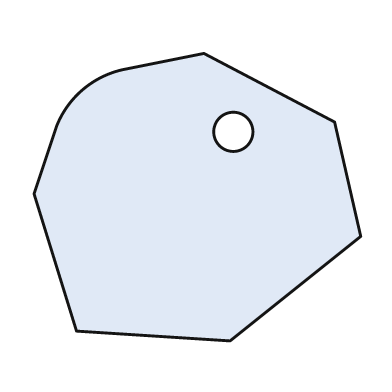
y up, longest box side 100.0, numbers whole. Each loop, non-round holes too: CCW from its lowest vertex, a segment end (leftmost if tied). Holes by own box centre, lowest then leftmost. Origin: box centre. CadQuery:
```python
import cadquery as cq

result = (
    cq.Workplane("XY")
    .moveTo(10.0, -44.0)
    .lineTo(50.0, -12.0)
    .lineTo(42.0, 23.0)
    .lineTo(2.0, 44.0)
    .lineTo(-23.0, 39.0)
    .threePointArc((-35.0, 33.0), (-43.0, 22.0))
    .lineTo(-50.0, 1.0)
    .lineTo(-37.0, -41.0)
    .close()
    .moveTo(11.0, 20.0)
    .circle(6.0)
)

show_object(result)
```